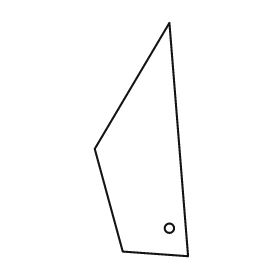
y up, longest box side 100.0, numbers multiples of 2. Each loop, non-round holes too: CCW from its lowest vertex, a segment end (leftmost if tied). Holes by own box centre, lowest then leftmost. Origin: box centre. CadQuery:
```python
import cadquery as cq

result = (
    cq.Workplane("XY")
    .moveTo(20.0, -50.0)
    .lineTo(12.0, 50.0)
    .lineTo(-20.0, -4.0)
    .lineTo(-8.0, -48.0)
    .close()
    .moveTo(12.0, -38.0)
    .circle(2.0)
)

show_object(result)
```